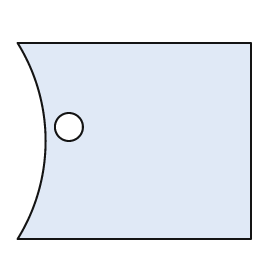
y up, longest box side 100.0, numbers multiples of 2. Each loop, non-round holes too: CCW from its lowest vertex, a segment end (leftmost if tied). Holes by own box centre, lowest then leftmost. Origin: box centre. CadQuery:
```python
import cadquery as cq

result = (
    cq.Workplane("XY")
    .moveTo(-50.0, -42.0)
    .lineTo(50.0, -42.0)
    .lineTo(50.0, 42.0)
    .lineTo(-50.0, 42.0)
    .threePointArc((-38.0, 0.0), (-50.0, -42.0))
    .close()
    .moveTo(-28.0, 6.0)
    .circle(6.0)
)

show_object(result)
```